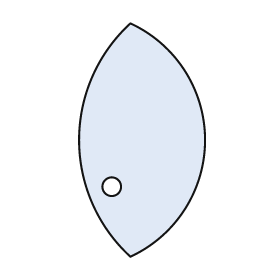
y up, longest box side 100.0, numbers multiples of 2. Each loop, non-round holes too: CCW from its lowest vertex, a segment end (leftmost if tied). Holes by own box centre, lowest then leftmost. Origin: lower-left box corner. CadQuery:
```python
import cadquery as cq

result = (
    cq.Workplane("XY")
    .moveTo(22.0, 0.0)
    .threePointArc((54.0, 50.0), (22.0, 100.0))
    .threePointArc((0.0, 50.0), (22.0, 0.0))
    .close()
    .moveTo(14.0, 30.0)
    .circle(4.0)
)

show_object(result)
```